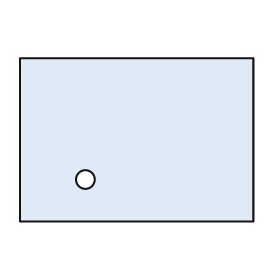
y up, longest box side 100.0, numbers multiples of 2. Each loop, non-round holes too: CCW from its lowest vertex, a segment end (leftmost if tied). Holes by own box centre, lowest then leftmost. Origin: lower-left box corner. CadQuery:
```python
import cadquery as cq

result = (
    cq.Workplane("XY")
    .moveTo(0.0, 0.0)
    .lineTo(100.0, 0.0)
    .lineTo(100.0, 70.0)
    .lineTo(0.0, 70.0)
    .close()
    .moveTo(28.0, 18.0)
    .circle(4.0)
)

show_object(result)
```